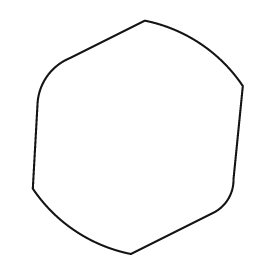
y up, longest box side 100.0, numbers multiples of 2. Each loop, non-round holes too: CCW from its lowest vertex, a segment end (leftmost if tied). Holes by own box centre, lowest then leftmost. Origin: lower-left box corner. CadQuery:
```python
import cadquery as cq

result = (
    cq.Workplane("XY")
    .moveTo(42.0, 0.0)
    .lineTo(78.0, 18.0)
    .threePointArc((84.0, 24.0), (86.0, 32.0))
    .lineTo(90.0, 72.0)
    .threePointArc((72.0, 90.0), (48.0, 100.0))
    .lineTo(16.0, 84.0)
    .threePointArc((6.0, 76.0), (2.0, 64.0))
    .lineTo(0.0, 28.0)
    .threePointArc((18.0, 10.0), (42.0, 0.0))
    .close()
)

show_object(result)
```